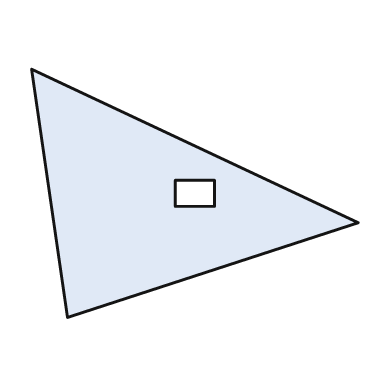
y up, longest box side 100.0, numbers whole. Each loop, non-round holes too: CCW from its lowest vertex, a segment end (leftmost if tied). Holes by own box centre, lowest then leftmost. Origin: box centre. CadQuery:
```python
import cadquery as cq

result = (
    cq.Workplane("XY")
    .moveTo(-39.0, -38.0)
    .lineTo(50.0, -9.0)
    .lineTo(-50.0, 38.0)
    .close()
    .moveTo(-6.0, -4.0)
    .lineTo(6.0, -4.0)
    .lineTo(6.0, 4.0)
    .lineTo(-6.0, 4.0)
    .close()
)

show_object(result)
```